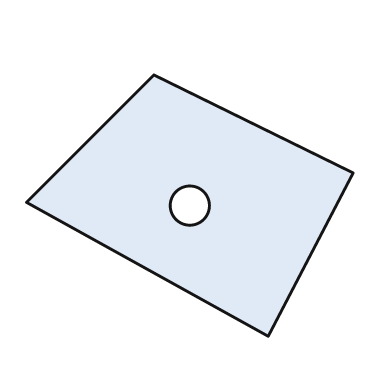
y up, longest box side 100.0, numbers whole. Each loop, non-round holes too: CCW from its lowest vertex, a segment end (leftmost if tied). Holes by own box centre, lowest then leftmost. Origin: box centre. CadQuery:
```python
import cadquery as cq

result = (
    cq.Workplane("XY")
    .moveTo(24.0, -40.0)
    .lineTo(50.0, 10.0)
    .lineTo(-11.0, 40.0)
    .lineTo(-50.0, 1.0)
    .close()
    .moveTo(0.0, 0.0)
    .circle(6.0)
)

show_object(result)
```